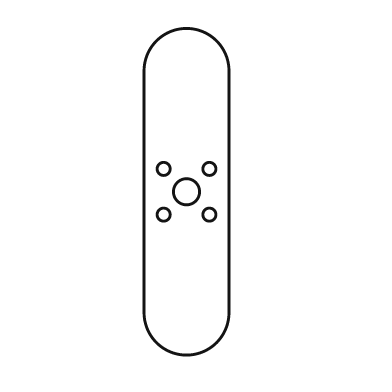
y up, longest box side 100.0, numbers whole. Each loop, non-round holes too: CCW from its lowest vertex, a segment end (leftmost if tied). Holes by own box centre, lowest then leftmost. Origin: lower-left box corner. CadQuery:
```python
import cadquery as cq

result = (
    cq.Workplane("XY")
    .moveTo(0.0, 13.0)
    .threePointArc((13.0, 0.0), (26.0, 13.0))
    .lineTo(26.0, 87.0)
    .threePointArc((13.0, 100.0), (0.0, 87.0))
    .close()
    .moveTo(6.0, 43.0)
    .circle(2.0)
    .moveTo(20.0, 43.0)
    .circle(2.0)
    .moveTo(13.0, 50.0)
    .circle(4.0)
    .moveTo(6.0, 57.0)
    .circle(2.0)
    .moveTo(20.0, 57.0)
    .circle(2.0)
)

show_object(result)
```